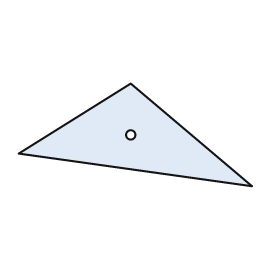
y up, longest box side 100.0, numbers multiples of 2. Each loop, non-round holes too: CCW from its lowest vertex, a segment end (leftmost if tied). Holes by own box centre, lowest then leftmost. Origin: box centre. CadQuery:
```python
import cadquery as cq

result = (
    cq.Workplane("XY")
    .moveTo(50.0, -22.0)
    .lineTo(-2.0, 22.0)
    .lineTo(-50.0, -8.0)
    .close()
    .moveTo(-2.0, 0.0)
    .circle(2.0)
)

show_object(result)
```